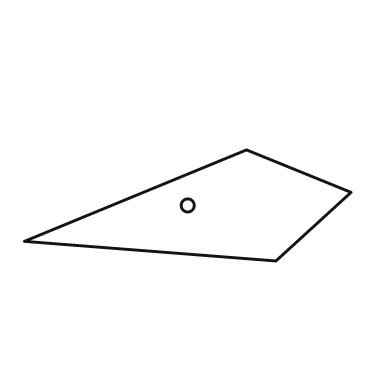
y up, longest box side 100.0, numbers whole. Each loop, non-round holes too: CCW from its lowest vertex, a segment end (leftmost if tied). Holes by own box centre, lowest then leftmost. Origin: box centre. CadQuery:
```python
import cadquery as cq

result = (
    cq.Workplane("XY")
    .moveTo(27.0, -17.0)
    .lineTo(50.0, 4.0)
    .lineTo(18.0, 17.0)
    .lineTo(-50.0, -11.0)
    .close()
    .moveTo(0.0, 0.0)
    .circle(2.0)
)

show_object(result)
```